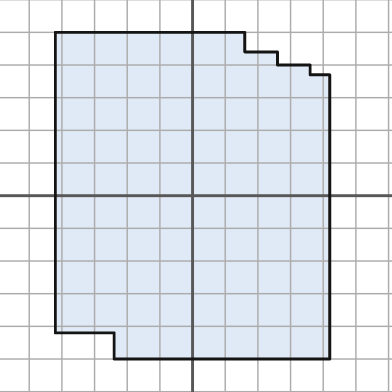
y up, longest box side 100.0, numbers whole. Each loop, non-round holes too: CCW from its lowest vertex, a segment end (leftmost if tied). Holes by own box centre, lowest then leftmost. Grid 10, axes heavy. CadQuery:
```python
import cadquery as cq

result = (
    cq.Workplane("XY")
    .moveTo(-24.0, -50.0)
    .lineTo(42.0, -50.0)
    .lineTo(42.0, 37.0)
    .lineTo(36.0, 37.0)
    .lineTo(36.0, 40.0)
    .lineTo(26.0, 40.0)
    .lineTo(26.0, 44.0)
    .lineTo(16.0, 44.0)
    .lineTo(16.0, 50.0)
    .lineTo(-42.0, 50.0)
    .lineTo(-42.0, -42.0)
    .lineTo(-24.0, -42.0)
    .close()
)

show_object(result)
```